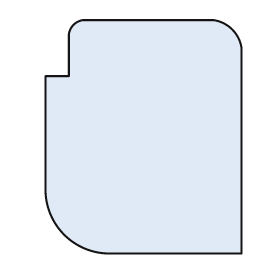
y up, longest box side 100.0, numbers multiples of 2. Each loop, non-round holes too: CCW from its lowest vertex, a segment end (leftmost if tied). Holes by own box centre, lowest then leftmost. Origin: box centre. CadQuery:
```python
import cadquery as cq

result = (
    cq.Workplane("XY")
    .moveTo(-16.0, -50.0)
    .lineTo(42.0, -50.0)
    .lineTo(42.0, 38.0)
    .threePointArc((38.0, 46.0), (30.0, 50.0))
    .lineTo(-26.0, 50.0)
    .threePointArc((-30.0, 48.0), (-32.0, 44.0))
    .lineTo(-32.0, 26.0)
    .lineTo(-42.0, 26.0)
    .lineTo(-42.0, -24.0)
    .threePointArc((-34.0, -42.0), (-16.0, -50.0))
    .close()
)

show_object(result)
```